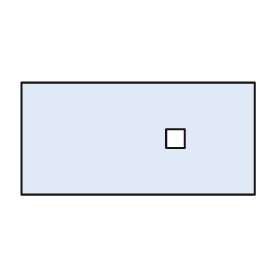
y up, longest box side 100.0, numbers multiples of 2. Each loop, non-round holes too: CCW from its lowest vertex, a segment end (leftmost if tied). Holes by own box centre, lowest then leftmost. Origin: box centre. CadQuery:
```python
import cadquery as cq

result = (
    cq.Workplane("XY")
    .moveTo(-50.0, -24.0)
    .lineTo(50.0, -24.0)
    .lineTo(50.0, 24.0)
    .lineTo(-50.0, 24.0)
    .close()
    .moveTo(12.0, -4.0)
    .lineTo(20.0, -4.0)
    .lineTo(20.0, 4.0)
    .lineTo(12.0, 4.0)
    .close()
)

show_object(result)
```